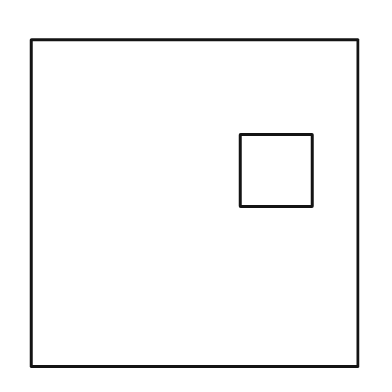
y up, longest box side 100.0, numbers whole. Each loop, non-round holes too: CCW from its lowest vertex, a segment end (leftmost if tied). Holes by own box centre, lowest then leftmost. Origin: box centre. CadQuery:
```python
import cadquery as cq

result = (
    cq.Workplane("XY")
    .moveTo(-50.0, -50.0)
    .lineTo(50.0, -50.0)
    .lineTo(50.0, 50.0)
    .lineTo(-50.0, 50.0)
    .close()
    .moveTo(14.0, -1.0)
    .lineTo(36.0, -1.0)
    .lineTo(36.0, 21.0)
    .lineTo(14.0, 21.0)
    .close()
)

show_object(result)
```